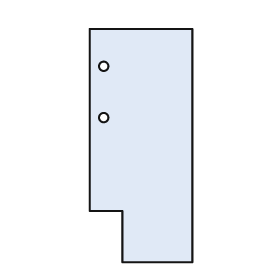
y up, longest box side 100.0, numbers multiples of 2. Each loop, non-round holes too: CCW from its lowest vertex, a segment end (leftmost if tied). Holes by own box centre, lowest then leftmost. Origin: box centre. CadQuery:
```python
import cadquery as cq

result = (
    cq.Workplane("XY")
    .moveTo(-8.0, -50.0)
    .lineTo(22.0, -50.0)
    .lineTo(22.0, 50.0)
    .lineTo(-22.0, 50.0)
    .lineTo(-22.0, -28.0)
    .lineTo(-8.0, -28.0)
    .close()
    .moveTo(-16.0, 12.0)
    .circle(2.0)
    .moveTo(-16.0, 34.0)
    .circle(2.0)
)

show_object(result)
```